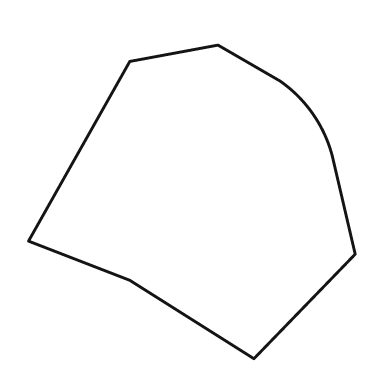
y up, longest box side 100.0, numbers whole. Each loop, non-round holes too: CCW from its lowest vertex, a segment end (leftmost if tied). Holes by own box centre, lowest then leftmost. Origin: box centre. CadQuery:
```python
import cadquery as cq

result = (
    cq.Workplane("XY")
    .moveTo(19.0, -48.0)
    .lineTo(50.0, -16.0)
    .lineTo(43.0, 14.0)
    .threePointArc((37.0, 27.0), (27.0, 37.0))
    .lineTo(8.0, 48.0)
    .lineTo(-19.0, 43.0)
    .lineTo(-50.0, -12.0)
    .lineTo(-19.0, -24.0)
    .close()
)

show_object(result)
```